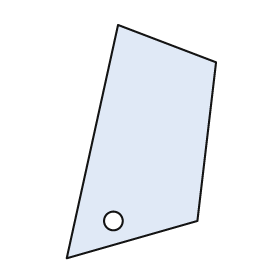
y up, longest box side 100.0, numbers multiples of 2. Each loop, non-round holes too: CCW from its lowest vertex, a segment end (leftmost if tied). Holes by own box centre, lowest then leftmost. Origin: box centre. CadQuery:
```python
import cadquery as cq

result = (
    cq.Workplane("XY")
    .moveTo(-32.0, -50.0)
    .lineTo(24.0, -34.0)
    .lineTo(32.0, 34.0)
    .lineTo(-10.0, 50.0)
    .close()
    .moveTo(-12.0, -34.0)
    .circle(4.0)
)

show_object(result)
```